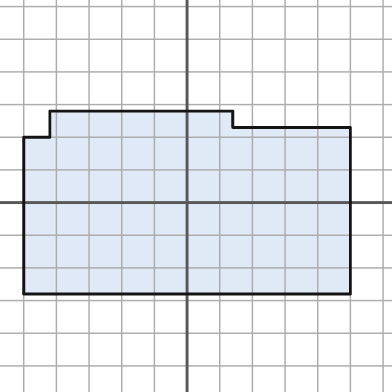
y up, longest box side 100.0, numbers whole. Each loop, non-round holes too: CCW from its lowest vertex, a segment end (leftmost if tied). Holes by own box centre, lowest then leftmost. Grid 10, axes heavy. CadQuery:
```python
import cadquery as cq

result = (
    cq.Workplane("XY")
    .moveTo(-50.0, -28.0)
    .lineTo(50.0, -28.0)
    .lineTo(50.0, 23.0)
    .lineTo(14.0, 23.0)
    .lineTo(14.0, 28.0)
    .lineTo(-42.0, 28.0)
    .lineTo(-42.0, 20.0)
    .lineTo(-50.0, 20.0)
    .close()
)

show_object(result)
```